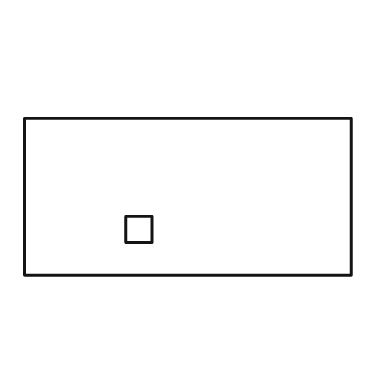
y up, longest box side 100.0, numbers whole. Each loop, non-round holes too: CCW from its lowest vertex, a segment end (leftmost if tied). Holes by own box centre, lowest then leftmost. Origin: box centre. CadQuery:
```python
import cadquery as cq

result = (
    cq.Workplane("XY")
    .moveTo(-50.0, -24.0)
    .lineTo(50.0, -24.0)
    .lineTo(50.0, 24.0)
    .lineTo(-50.0, 24.0)
    .close()
    .moveTo(-19.0, -14.0)
    .lineTo(-11.0, -14.0)
    .lineTo(-11.0, -6.0)
    .lineTo(-19.0, -6.0)
    .close()
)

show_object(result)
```